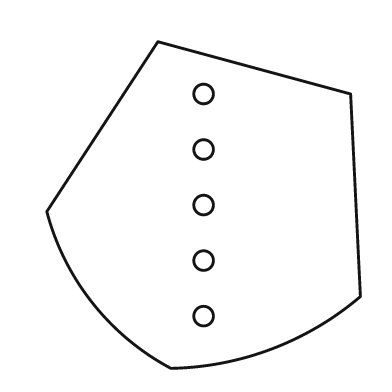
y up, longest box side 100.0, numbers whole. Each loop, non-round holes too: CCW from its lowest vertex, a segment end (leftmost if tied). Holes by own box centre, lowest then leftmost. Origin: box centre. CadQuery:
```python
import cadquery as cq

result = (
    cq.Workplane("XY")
    .moveTo(-10.0, -50.0)
    .threePointArc((21.0, -44.0), (48.0, -28.0))
    .lineTo(45.0, 34.0)
    .lineTo(-14.0, 50.0)
    .lineTo(-48.0, -2.0)
    .threePointArc((-34.0, -30.0), (-10.0, -50.0))
    .close()
    .moveTo(0.0, -34.0)
    .circle(3.0)
    .moveTo(0.0, -17.0)
    .circle(3.0)
    .moveTo(0.0, 0.0)
    .circle(3.0)
    .moveTo(0.0, 17.0)
    .circle(3.0)
    .moveTo(0.0, 34.0)
    .circle(3.0)
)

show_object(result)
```